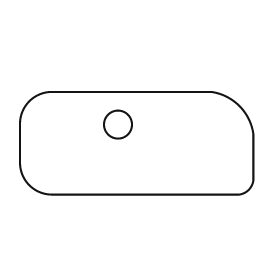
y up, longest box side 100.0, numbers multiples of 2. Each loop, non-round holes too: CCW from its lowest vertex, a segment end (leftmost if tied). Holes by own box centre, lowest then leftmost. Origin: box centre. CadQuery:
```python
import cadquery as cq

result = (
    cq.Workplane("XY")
    .moveTo(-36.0, -22.0)
    .lineTo(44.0, -22.0)
    .threePointArc((48.0, -20.0), (50.0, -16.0))
    .lineTo(50.0, 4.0)
    .threePointArc((44.0, 16.0), (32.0, 22.0))
    .lineTo(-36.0, 22.0)
    .threePointArc((-46.0, 18.0), (-50.0, 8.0))
    .lineTo(-50.0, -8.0)
    .threePointArc((-46.0, -18.0), (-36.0, -22.0))
    .close()
    .moveTo(-8.0, 8.0)
    .circle(6.0)
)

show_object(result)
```